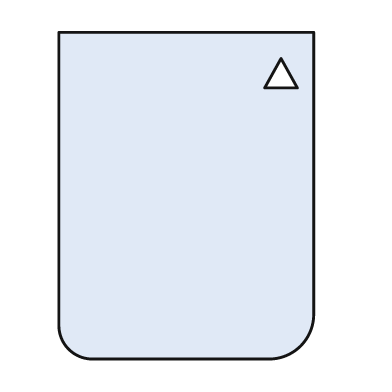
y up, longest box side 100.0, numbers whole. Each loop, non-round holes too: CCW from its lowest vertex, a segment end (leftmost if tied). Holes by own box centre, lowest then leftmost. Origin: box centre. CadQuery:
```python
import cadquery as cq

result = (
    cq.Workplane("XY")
    .moveTo(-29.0, -50.0)
    .lineTo(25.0, -50.0)
    .threePointArc((35.0, -46.0), (39.0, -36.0))
    .lineTo(39.0, 50.0)
    .lineTo(-39.0, 50.0)
    .lineTo(-39.0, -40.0)
    .threePointArc((-36.0, -47.0), (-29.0, -50.0))
    .close()
    .moveTo(24.0, 33.0)
    .lineTo(34.0, 33.0)
    .lineTo(29.0, 42.0)
    .close()
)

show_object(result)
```